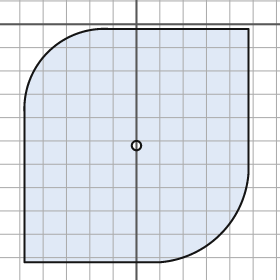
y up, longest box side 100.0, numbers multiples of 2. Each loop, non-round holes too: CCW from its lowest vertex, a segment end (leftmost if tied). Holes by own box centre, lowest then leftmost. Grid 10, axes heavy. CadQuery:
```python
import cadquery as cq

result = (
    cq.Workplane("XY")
    .moveTo(-48.0, -102.0)
    .lineTo(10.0, -102.0)
    .threePointArc((36.0, -90.0), (48.0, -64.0))
    .lineTo(48.0, -2.0)
    .lineTo(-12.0, -2.0)
    .threePointArc((-38.0, -12.0), (-48.0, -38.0))
    .close()
    .moveTo(0.0, -52.0)
    .circle(2.0)
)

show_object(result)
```